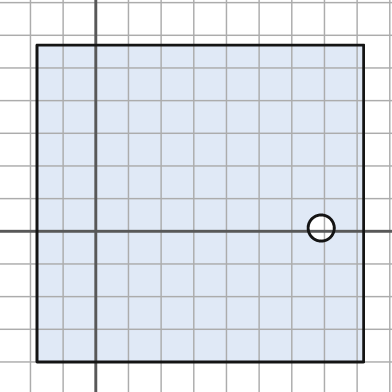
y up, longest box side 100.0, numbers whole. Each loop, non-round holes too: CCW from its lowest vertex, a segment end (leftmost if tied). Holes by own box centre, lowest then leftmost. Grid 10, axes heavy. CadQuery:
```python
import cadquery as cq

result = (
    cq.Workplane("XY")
    .moveTo(-18.0, -40.0)
    .lineTo(82.0, -40.0)
    .lineTo(82.0, 57.0)
    .lineTo(-18.0, 57.0)
    .close()
    .moveTo(69.0, 1.0)
    .circle(4.0)
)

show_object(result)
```